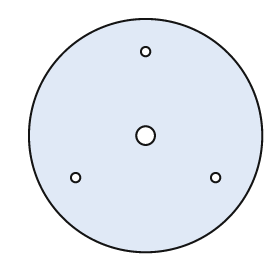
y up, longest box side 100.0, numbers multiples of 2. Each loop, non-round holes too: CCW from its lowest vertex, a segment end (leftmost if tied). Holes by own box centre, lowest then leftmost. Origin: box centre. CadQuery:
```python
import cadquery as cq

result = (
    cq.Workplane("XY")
    .moveTo(0.0, 0.0)
    .circle(50.0)
    .moveTo(-30.0, -18.0)
    .circle(2.0)
    .moveTo(30.0, -18.0)
    .circle(2.0)
    .moveTo(0.0, 0.0)
    .circle(4.0)
    .moveTo(0.0, 36.0)
    .circle(2.0)
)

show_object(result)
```